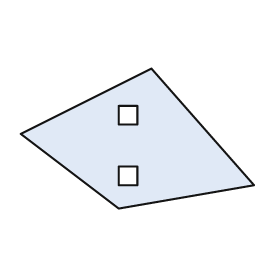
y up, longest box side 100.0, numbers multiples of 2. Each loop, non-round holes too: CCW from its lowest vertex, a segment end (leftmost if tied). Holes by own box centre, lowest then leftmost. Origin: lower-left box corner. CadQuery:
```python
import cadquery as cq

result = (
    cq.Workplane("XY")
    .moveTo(42.0, 0.0)
    .lineTo(100.0, 10.0)
    .lineTo(56.0, 60.0)
    .lineTo(0.0, 32.0)
    .close()
    .moveTo(42.0, 10.0)
    .lineTo(50.0, 10.0)
    .lineTo(50.0, 18.0)
    .lineTo(42.0, 18.0)
    .close()
    .moveTo(42.0, 36.0)
    .lineTo(50.0, 36.0)
    .lineTo(50.0, 44.0)
    .lineTo(42.0, 44.0)
    .close()
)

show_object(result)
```